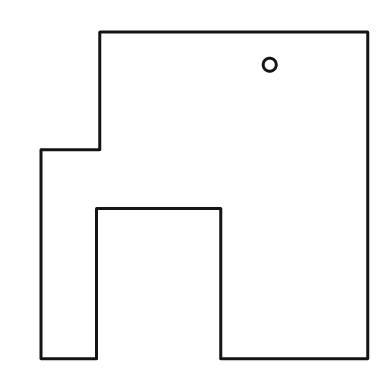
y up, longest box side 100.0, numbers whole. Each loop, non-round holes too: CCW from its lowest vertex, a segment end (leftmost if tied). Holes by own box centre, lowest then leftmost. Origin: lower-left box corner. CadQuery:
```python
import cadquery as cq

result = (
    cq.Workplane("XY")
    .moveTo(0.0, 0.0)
    .lineTo(17.0, 0.0)
    .lineTo(17.0, 46.0)
    .lineTo(55.0, 46.0)
    .lineTo(55.0, 0.0)
    .lineTo(100.0, 0.0)
    .lineTo(100.0, 100.0)
    .lineTo(18.0, 100.0)
    .lineTo(18.0, 64.0)
    .lineTo(0.0, 64.0)
    .close()
    .moveTo(70.0, 90.0)
    .circle(2.0)
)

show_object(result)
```